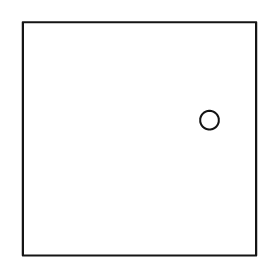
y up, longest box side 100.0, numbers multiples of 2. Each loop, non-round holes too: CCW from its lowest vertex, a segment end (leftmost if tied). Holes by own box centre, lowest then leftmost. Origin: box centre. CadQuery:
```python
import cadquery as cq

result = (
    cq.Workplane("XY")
    .moveTo(-50.0, -50.0)
    .lineTo(50.0, -50.0)
    .lineTo(50.0, 50.0)
    .lineTo(-50.0, 50.0)
    .close()
    .moveTo(30.0, 8.0)
    .circle(4.0)
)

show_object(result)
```